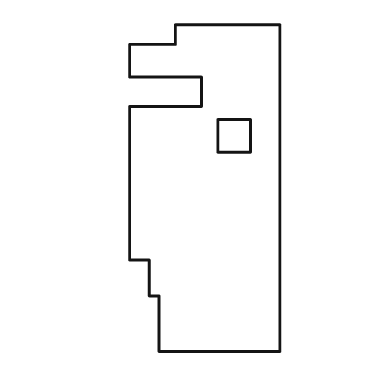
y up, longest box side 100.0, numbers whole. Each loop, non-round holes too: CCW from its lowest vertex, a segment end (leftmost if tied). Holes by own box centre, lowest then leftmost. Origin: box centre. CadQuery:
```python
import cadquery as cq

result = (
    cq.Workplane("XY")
    .moveTo(-14.0, -50.0)
    .lineTo(23.0, -50.0)
    .lineTo(23.0, 50.0)
    .lineTo(-9.0, 50.0)
    .lineTo(-9.0, 44.0)
    .lineTo(-23.0, 44.0)
    .lineTo(-23.0, 34.0)
    .lineTo(-1.0, 34.0)
    .lineTo(-1.0, 25.0)
    .lineTo(-23.0, 25.0)
    .lineTo(-23.0, -22.0)
    .lineTo(-17.0, -22.0)
    .lineTo(-17.0, -33.0)
    .lineTo(-14.0, -33.0)
    .close()
    .moveTo(4.0, 11.0)
    .lineTo(14.0, 11.0)
    .lineTo(14.0, 21.0)
    .lineTo(4.0, 21.0)
    .close()
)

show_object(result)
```